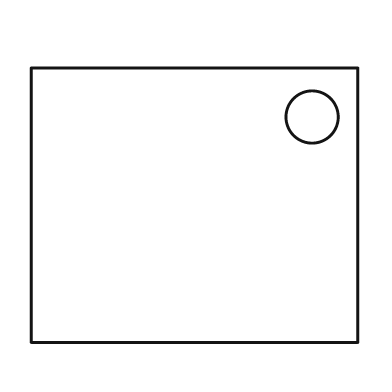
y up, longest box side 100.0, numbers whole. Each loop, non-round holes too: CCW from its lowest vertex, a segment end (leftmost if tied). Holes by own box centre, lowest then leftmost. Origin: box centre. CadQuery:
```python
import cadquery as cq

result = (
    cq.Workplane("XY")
    .moveTo(-50.0, -42.0)
    .lineTo(50.0, -42.0)
    .lineTo(50.0, 42.0)
    .lineTo(-50.0, 42.0)
    .close()
    .moveTo(36.0, 27.0)
    .circle(8.0)
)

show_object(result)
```